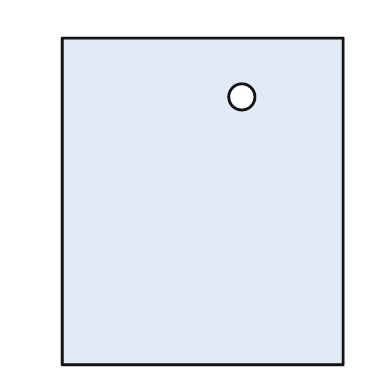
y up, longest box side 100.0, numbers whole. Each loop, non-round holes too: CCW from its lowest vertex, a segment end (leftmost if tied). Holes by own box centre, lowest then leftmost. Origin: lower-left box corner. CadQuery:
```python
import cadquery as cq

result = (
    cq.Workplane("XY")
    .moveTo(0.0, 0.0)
    .lineTo(86.0, 0.0)
    .lineTo(86.0, 100.0)
    .lineTo(0.0, 100.0)
    .close()
    .moveTo(55.0, 82.0)
    .circle(4.0)
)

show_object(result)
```